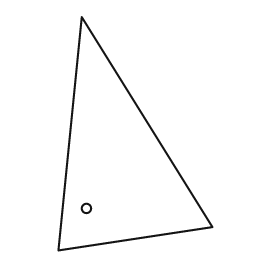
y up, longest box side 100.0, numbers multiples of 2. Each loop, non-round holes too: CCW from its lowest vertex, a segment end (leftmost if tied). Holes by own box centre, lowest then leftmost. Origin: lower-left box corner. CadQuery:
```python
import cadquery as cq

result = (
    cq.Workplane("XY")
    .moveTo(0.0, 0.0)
    .lineTo(66.0, 10.0)
    .lineTo(10.0, 100.0)
    .close()
    .moveTo(12.0, 18.0)
    .circle(2.0)
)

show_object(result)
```